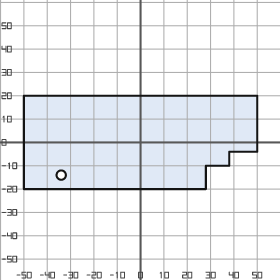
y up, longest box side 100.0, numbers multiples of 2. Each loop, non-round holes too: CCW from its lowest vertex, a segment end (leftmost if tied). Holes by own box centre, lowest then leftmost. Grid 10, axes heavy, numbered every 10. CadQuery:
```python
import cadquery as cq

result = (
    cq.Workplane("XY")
    .moveTo(-50.0, -20.0)
    .lineTo(28.0, -20.0)
    .lineTo(28.0, -10.0)
    .lineTo(38.0, -10.0)
    .lineTo(38.0, -4.0)
    .lineTo(50.0, -4.0)
    .lineTo(50.0, 20.0)
    .lineTo(-50.0, 20.0)
    .close()
    .moveTo(-34.0, -14.0)
    .circle(2.0)
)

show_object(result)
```